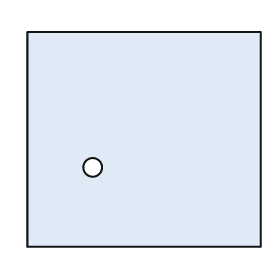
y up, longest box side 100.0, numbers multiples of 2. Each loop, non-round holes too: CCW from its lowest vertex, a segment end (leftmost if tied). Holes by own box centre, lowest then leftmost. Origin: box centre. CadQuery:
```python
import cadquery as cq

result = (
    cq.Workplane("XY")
    .moveTo(-50.0, -46.0)
    .lineTo(50.0, -46.0)
    .lineTo(50.0, 46.0)
    .lineTo(-50.0, 46.0)
    .close()
    .moveTo(-22.0, -12.0)
    .circle(4.0)
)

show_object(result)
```